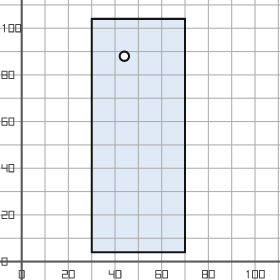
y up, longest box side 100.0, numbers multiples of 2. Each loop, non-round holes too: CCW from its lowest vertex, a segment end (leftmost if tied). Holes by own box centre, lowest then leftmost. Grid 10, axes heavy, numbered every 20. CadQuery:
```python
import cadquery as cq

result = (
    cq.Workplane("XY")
    .moveTo(30.0, 4.0)
    .lineTo(70.0, 4.0)
    .lineTo(70.0, 104.0)
    .lineTo(30.0, 104.0)
    .close()
    .moveTo(44.0, 88.0)
    .circle(2.0)
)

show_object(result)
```